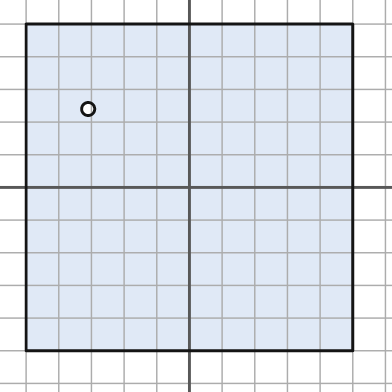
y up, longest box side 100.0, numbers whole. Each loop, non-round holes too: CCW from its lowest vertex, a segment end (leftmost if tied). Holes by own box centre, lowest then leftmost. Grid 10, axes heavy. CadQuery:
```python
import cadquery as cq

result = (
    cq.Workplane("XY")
    .moveTo(-50.0, -50.0)
    .lineTo(50.0, -50.0)
    .lineTo(50.0, 50.0)
    .lineTo(-50.0, 50.0)
    .close()
    .moveTo(-31.0, 24.0)
    .circle(2.0)
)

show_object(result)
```